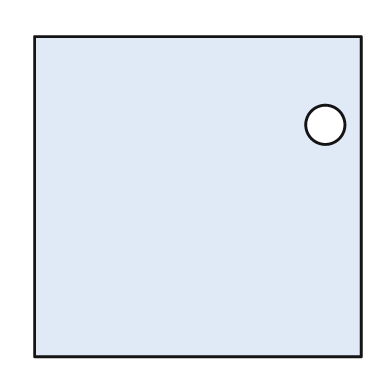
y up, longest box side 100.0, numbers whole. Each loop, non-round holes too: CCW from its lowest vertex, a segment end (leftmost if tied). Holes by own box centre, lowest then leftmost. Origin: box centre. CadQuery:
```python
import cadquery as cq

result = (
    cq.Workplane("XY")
    .moveTo(-50.0, -49.0)
    .lineTo(50.0, -49.0)
    .lineTo(50.0, 49.0)
    .lineTo(-50.0, 49.0)
    .close()
    .moveTo(39.0, 22.0)
    .circle(6.0)
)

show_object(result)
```